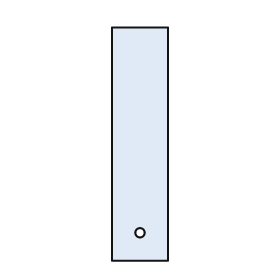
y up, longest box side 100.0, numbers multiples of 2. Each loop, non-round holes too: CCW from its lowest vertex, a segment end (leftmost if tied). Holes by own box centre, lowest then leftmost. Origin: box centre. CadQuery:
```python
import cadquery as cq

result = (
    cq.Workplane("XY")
    .moveTo(-12.0, -50.0)
    .lineTo(12.0, -50.0)
    .lineTo(12.0, 50.0)
    .lineTo(-12.0, 50.0)
    .close()
    .moveTo(0.0, -38.0)
    .circle(2.0)
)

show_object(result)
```